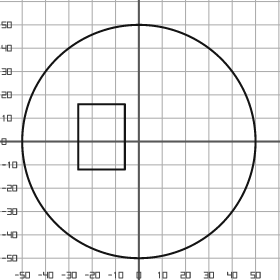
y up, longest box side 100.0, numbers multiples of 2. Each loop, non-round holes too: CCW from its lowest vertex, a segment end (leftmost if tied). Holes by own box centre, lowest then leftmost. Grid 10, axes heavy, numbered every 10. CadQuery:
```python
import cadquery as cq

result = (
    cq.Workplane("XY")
    .moveTo(0.0, 0.0)
    .circle(50.0)
    .moveTo(-26.0, -12.0)
    .lineTo(-6.0, -12.0)
    .lineTo(-6.0, 16.0)
    .lineTo(-26.0, 16.0)
    .close()
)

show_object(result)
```